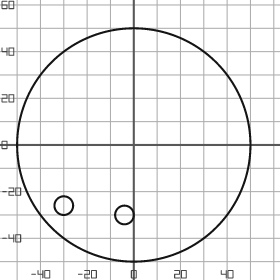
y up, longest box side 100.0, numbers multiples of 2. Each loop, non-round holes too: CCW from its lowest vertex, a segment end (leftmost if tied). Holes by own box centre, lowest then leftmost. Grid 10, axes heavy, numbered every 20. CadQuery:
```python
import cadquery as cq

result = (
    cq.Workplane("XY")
    .moveTo(0.0, 0.0)
    .circle(50.0)
    .moveTo(-4.0, -30.0)
    .circle(4.0)
    .moveTo(-30.0, -26.0)
    .circle(4.0)
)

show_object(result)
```